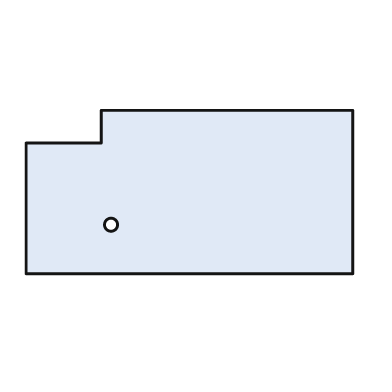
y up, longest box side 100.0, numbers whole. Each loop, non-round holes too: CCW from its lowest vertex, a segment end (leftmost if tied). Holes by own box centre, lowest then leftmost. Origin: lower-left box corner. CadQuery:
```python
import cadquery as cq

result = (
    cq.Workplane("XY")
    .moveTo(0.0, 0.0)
    .lineTo(100.0, 0.0)
    .lineTo(100.0, 50.0)
    .lineTo(23.0, 50.0)
    .lineTo(23.0, 40.0)
    .lineTo(0.0, 40.0)
    .close()
    .moveTo(26.0, 15.0)
    .circle(2.0)
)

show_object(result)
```